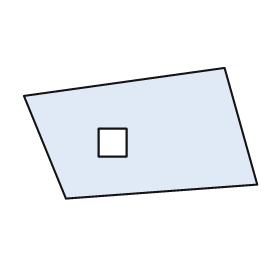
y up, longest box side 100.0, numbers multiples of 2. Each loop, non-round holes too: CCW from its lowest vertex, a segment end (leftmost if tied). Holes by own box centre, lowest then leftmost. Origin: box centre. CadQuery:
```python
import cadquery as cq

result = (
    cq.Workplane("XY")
    .moveTo(-32.0, -28.0)
    .lineTo(50.0, -22.0)
    .lineTo(36.0, 28.0)
    .lineTo(-50.0, 16.0)
    .close()
    .moveTo(-18.0, -10.0)
    .lineTo(-6.0, -10.0)
    .lineTo(-6.0, 2.0)
    .lineTo(-18.0, 2.0)
    .close()
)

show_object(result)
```